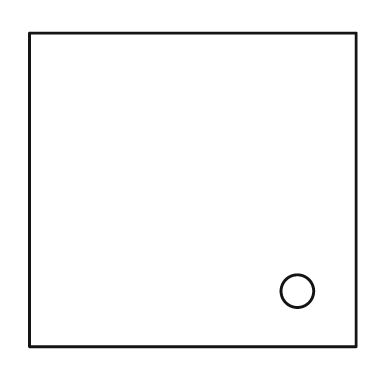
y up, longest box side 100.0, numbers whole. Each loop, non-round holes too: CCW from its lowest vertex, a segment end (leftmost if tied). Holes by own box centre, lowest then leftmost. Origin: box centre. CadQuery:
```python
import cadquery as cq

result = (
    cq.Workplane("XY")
    .moveTo(-50.0, -48.0)
    .lineTo(50.0, -48.0)
    .lineTo(50.0, 48.0)
    .lineTo(-50.0, 48.0)
    .close()
    .moveTo(32.0, -31.0)
    .circle(5.0)
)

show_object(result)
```